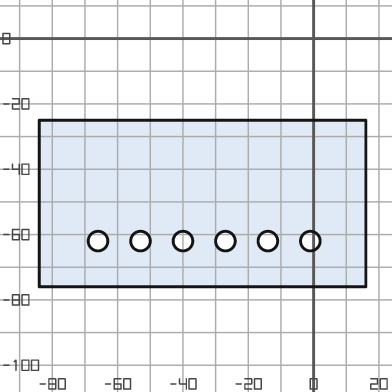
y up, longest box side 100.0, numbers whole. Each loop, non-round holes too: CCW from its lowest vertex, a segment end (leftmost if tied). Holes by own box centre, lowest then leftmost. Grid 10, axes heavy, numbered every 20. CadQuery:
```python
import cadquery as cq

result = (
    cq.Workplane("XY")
    .moveTo(-84.0, -76.0)
    .lineTo(16.0, -76.0)
    .lineTo(16.0, -25.0)
    .lineTo(-84.0, -25.0)
    .close()
    .moveTo(-66.0, -62.0)
    .circle(3.0)
    .moveTo(-53.0, -62.0)
    .circle(3.0)
    .moveTo(-40.0, -62.0)
    .circle(3.0)
    .moveTo(-27.0, -62.0)
    .circle(3.0)
    .moveTo(-14.0, -62.0)
    .circle(3.0)
    .moveTo(-1.0, -62.0)
    .circle(3.0)
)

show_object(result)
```